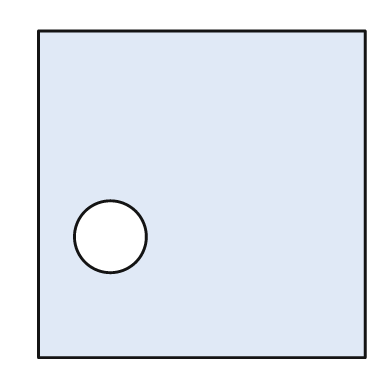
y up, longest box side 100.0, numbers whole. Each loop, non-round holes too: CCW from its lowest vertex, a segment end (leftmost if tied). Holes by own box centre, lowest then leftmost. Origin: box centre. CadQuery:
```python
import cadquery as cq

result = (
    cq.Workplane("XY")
    .moveTo(-50.0, -50.0)
    .lineTo(50.0, -50.0)
    .lineTo(50.0, 50.0)
    .lineTo(-50.0, 50.0)
    .close()
    .moveTo(-28.0, -13.0)
    .circle(11.0)
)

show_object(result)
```